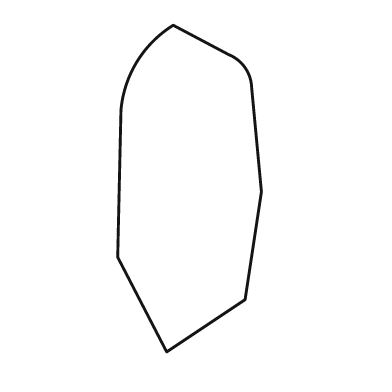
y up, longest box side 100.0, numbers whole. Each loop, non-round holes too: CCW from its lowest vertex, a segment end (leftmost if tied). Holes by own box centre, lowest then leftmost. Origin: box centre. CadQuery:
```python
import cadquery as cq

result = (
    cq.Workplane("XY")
    .moveTo(-7.0, -50.0)
    .lineTo(17.0, -34.0)
    .lineTo(22.0, -1.0)
    .lineTo(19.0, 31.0)
    .threePointArc((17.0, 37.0), (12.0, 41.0))
    .lineTo(-5.0, 50.0)
    .threePointArc((-16.0, 39.0), (-21.0, 24.0))
    .lineTo(-22.0, -21.0)
    .close()
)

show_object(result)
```